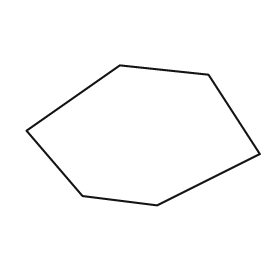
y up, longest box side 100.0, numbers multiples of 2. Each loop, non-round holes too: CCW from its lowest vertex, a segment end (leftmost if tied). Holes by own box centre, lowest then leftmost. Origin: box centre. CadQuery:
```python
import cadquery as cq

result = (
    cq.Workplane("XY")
    .moveTo(6.0, -30.0)
    .lineTo(50.0, -8.0)
    .lineTo(28.0, 26.0)
    .lineTo(-10.0, 30.0)
    .lineTo(-50.0, 2.0)
    .lineTo(-26.0, -26.0)
    .close()
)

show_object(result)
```